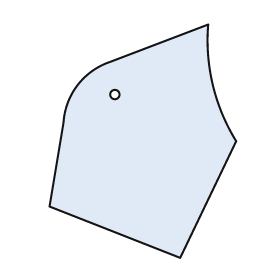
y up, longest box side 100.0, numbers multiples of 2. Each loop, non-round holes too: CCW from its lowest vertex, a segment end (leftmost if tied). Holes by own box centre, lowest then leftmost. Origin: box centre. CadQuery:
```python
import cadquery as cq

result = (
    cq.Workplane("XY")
    .moveTo(16.0, -50.0)
    .lineTo(40.0, 0.0)
    .threePointArc((30.0, 24.0), (28.0, 50.0))
    .lineTo(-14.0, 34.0)
    .threePointArc((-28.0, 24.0), (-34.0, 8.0))
    .lineTo(-40.0, -28.0)
    .close()
    .moveTo(-12.0, 20.0)
    .circle(2.0)
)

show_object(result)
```